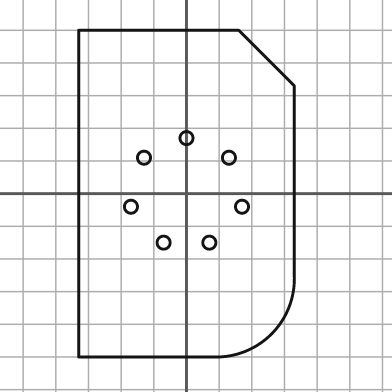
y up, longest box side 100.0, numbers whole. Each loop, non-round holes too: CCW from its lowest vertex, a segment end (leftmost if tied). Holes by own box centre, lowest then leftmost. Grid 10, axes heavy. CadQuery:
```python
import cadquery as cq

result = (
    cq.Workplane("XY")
    .moveTo(-33.0, -50.0)
    .lineTo(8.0, -50.0)
    .threePointArc((26.0, -43.0), (33.0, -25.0))
    .lineTo(33.0, 33.0)
    .lineTo(16.0, 50.0)
    .lineTo(-33.0, 50.0)
    .close()
    .moveTo(-7.0, -15.0)
    .circle(2.0)
    .moveTo(7.0, -15.0)
    .circle(2.0)
    .moveTo(-17.0, -4.0)
    .circle(2.0)
    .moveTo(17.0, -4.0)
    .circle(2.0)
    .moveTo(-13.0, 11.0)
    .circle(2.0)
    .moveTo(13.0, 11.0)
    .circle(2.0)
    .moveTo(0.0, 17.0)
    .circle(2.0)
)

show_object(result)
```